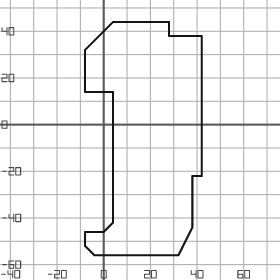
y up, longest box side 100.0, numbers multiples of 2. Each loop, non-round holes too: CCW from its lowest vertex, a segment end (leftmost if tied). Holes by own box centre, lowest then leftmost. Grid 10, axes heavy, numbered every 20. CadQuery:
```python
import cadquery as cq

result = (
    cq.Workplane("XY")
    .moveTo(-4.0, -56.0)
    .lineTo(32.0, -56.0)
    .lineTo(38.0, -44.0)
    .lineTo(38.0, -22.0)
    .lineTo(42.0, -22.0)
    .lineTo(42.0, 38.0)
    .lineTo(28.0, 38.0)
    .lineTo(28.0, 44.0)
    .lineTo(4.0, 44.0)
    .lineTo(-8.0, 32.0)
    .lineTo(-8.0, 14.0)
    .lineTo(4.0, 14.0)
    .lineTo(4.0, -42.0)
    .lineTo(0.0, -46.0)
    .lineTo(-8.0, -46.0)
    .lineTo(-8.0, -52.0)
    .close()
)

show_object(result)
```